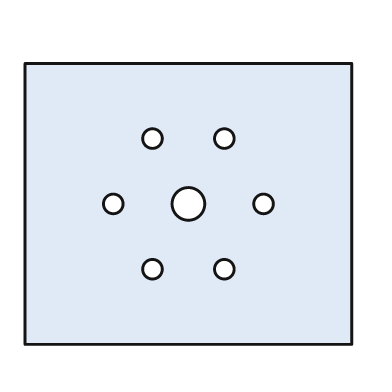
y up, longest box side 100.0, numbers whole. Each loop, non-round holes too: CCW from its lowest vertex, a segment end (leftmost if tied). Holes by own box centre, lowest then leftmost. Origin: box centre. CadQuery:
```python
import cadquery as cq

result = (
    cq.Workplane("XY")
    .moveTo(-50.0, -43.0)
    .lineTo(50.0, -43.0)
    .lineTo(50.0, 43.0)
    .lineTo(-50.0, 43.0)
    .close()
    .moveTo(-11.0, -20.0)
    .circle(3.0)
    .moveTo(11.0, -20.0)
    .circle(3.0)
    .moveTo(-23.0, 0.0)
    .circle(3.0)
    .moveTo(0.0, 0.0)
    .circle(5.0)
    .moveTo(23.0, 0.0)
    .circle(3.0)
    .moveTo(-11.0, 20.0)
    .circle(3.0)
    .moveTo(11.0, 20.0)
    .circle(3.0)
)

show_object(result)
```